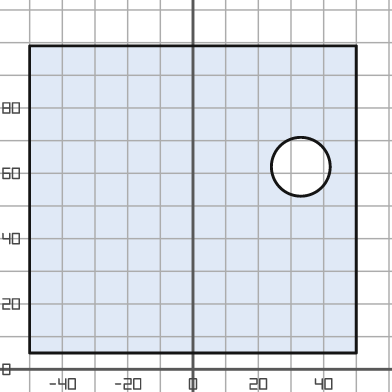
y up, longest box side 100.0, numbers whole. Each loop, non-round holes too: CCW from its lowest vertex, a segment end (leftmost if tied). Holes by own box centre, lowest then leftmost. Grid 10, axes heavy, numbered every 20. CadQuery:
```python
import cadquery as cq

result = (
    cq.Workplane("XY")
    .moveTo(-50.0, 5.0)
    .lineTo(50.0, 5.0)
    .lineTo(50.0, 99.0)
    .lineTo(-50.0, 99.0)
    .close()
    .moveTo(33.0, 62.0)
    .circle(9.0)
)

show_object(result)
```